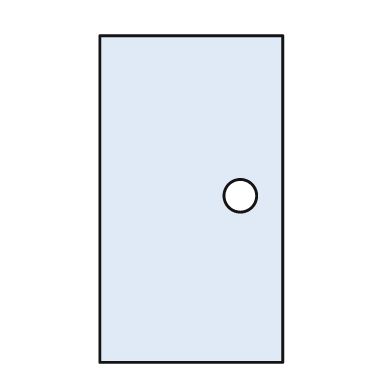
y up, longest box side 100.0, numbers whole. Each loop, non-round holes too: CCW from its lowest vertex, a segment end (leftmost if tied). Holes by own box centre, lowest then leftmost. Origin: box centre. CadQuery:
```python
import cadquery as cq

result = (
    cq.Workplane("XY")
    .moveTo(-28.0, -50.0)
    .lineTo(28.0, -50.0)
    .lineTo(28.0, 50.0)
    .lineTo(-28.0, 50.0)
    .close()
    .moveTo(15.0, 1.0)
    .circle(5.0)
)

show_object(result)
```